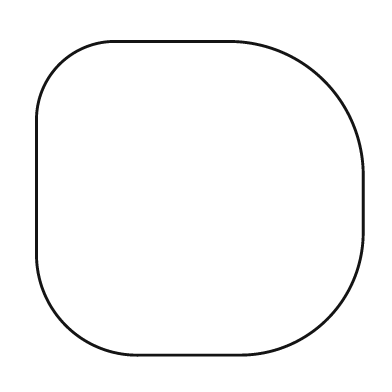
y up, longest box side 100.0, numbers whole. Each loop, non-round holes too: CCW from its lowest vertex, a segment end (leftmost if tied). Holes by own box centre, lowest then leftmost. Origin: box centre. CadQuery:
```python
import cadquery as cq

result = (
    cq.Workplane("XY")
    .moveTo(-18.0, -48.0)
    .lineTo(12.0, -48.0)
    .threePointArc((39.0, -37.0), (50.0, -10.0))
    .lineTo(50.0, 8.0)
    .threePointArc((38.0, 36.0), (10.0, 48.0))
    .lineTo(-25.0, 48.0)
    .threePointArc((-43.0, 41.0), (-50.0, 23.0))
    .lineTo(-50.0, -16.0)
    .threePointArc((-41.0, -39.0), (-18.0, -48.0))
    .close()
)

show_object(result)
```